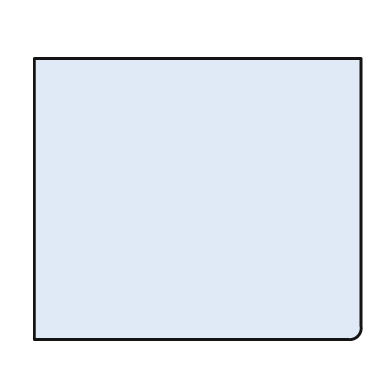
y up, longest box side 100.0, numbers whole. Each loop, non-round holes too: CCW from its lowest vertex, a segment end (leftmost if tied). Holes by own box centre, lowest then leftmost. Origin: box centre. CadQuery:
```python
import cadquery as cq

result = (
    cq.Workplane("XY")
    .moveTo(-50.0, -43.0)
    .lineTo(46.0, -43.0)
    .threePointArc((49.0, -42.0), (50.0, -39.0))
    .lineTo(50.0, 43.0)
    .lineTo(-50.0, 43.0)
    .close()
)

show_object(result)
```